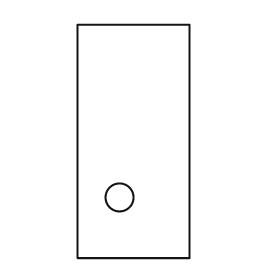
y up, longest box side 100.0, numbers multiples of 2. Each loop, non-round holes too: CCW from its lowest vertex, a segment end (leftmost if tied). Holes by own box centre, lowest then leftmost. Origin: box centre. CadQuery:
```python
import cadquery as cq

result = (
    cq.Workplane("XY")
    .moveTo(-24.0, -50.0)
    .lineTo(24.0, -50.0)
    .lineTo(24.0, 50.0)
    .lineTo(-24.0, 50.0)
    .close()
    .moveTo(-6.0, -24.0)
    .circle(6.0)
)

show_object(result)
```